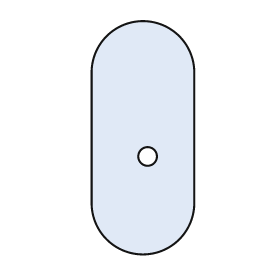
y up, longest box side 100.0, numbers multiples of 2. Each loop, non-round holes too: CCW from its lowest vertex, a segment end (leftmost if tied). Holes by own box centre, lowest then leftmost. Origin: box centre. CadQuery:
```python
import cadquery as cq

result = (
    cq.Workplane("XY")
    .moveTo(-22.0, -28.0)
    .threePointArc((0.0, -50.0), (22.0, -28.0))
    .lineTo(22.0, 28.0)
    .threePointArc((0.0, 50.0), (-22.0, 28.0))
    .close()
    .moveTo(2.0, -8.0)
    .circle(4.0)
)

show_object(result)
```